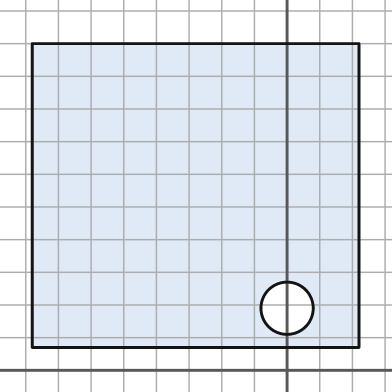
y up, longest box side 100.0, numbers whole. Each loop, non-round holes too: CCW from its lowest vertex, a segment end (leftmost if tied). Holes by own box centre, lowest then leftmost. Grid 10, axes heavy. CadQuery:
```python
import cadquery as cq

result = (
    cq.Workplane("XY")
    .moveTo(-78.0, 7.0)
    .lineTo(22.0, 7.0)
    .lineTo(22.0, 100.0)
    .lineTo(-78.0, 100.0)
    .close()
    .moveTo(0.0, 19.0)
    .circle(8.0)
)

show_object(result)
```